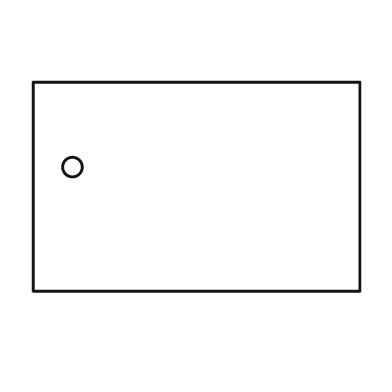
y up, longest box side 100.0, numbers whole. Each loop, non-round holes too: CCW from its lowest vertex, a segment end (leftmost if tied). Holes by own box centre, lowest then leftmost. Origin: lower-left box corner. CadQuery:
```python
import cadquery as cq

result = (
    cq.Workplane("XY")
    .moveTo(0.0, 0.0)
    .lineTo(100.0, 0.0)
    .lineTo(100.0, 64.0)
    .lineTo(0.0, 64.0)
    .close()
    .moveTo(12.0, 38.0)
    .circle(3.0)
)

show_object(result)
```